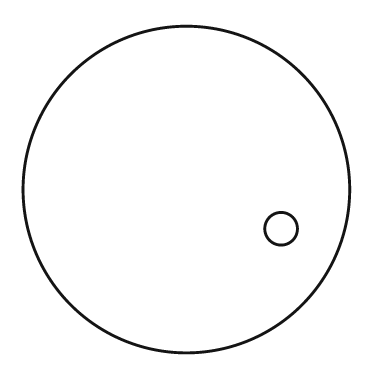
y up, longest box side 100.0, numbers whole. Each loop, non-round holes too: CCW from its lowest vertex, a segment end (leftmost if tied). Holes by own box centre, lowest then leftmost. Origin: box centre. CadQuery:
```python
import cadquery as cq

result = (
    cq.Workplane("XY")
    .moveTo(0.0, 0.0)
    .circle(50.0)
    .moveTo(29.0, -12.0)
    .circle(5.0)
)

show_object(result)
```